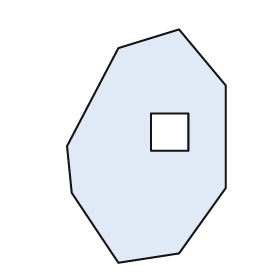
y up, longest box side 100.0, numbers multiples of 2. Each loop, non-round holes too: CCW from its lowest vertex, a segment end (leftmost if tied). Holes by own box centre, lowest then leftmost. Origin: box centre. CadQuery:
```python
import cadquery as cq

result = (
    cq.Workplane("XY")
    .moveTo(-12.0, -50.0)
    .lineTo(14.0, -46.0)
    .lineTo(34.0, -18.0)
    .lineTo(34.0, 26.0)
    .lineTo(14.0, 50.0)
    .lineTo(-12.0, 42.0)
    .lineTo(-34.0, 0.0)
    .lineTo(-32.0, -20.0)
    .close()
    .moveTo(2.0, -2.0)
    .lineTo(18.0, -2.0)
    .lineTo(18.0, 14.0)
    .lineTo(2.0, 14.0)
    .close()
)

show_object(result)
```